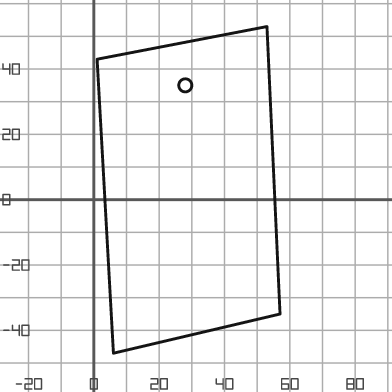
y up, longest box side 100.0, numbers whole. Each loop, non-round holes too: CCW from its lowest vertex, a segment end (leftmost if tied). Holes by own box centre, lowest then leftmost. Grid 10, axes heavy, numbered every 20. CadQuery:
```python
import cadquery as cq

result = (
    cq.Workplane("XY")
    .moveTo(6.0, -47.0)
    .lineTo(57.0, -35.0)
    .lineTo(53.0, 53.0)
    .lineTo(1.0, 43.0)
    .close()
    .moveTo(28.0, 35.0)
    .circle(2.0)
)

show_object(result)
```